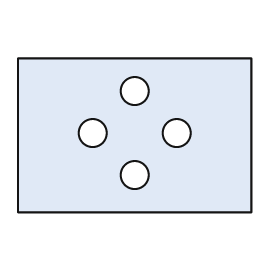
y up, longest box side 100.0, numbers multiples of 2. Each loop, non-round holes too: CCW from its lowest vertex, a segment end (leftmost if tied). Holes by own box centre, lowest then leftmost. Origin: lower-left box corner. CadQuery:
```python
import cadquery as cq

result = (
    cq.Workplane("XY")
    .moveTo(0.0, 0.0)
    .lineTo(100.0, 0.0)
    .lineTo(100.0, 66.0)
    .lineTo(0.0, 66.0)
    .close()
    .moveTo(50.0, 16.0)
    .circle(6.0)
    .moveTo(32.0, 34.0)
    .circle(6.0)
    .moveTo(68.0, 34.0)
    .circle(6.0)
    .moveTo(50.0, 52.0)
    .circle(6.0)
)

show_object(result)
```